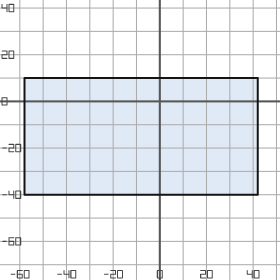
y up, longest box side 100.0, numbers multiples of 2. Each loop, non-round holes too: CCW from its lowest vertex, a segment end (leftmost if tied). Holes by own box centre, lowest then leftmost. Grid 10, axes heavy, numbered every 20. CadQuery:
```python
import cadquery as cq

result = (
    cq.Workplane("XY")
    .moveTo(-58.0, -40.0)
    .lineTo(42.0, -40.0)
    .lineTo(42.0, 10.0)
    .lineTo(-58.0, 10.0)
    .close()
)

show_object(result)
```